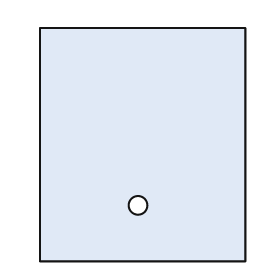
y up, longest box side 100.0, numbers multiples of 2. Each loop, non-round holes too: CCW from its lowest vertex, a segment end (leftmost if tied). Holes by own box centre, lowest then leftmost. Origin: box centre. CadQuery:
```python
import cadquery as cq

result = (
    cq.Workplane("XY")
    .moveTo(-44.0, -50.0)
    .lineTo(44.0, -50.0)
    .lineTo(44.0, 50.0)
    .lineTo(-44.0, 50.0)
    .close()
    .moveTo(-2.0, -26.0)
    .circle(4.0)
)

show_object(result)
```